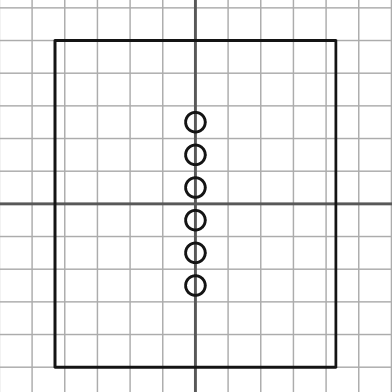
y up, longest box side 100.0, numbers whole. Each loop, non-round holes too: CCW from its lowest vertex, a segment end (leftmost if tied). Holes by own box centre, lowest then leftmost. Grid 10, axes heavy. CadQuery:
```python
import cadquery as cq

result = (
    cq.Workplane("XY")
    .moveTo(-43.0, -50.0)
    .lineTo(43.0, -50.0)
    .lineTo(43.0, 50.0)
    .lineTo(-43.0, 50.0)
    .close()
    .moveTo(0.0, -25.0)
    .circle(3.0)
    .moveTo(0.0, -15.0)
    .circle(3.0)
    .moveTo(0.0, -5.0)
    .circle(3.0)
    .moveTo(0.0, 5.0)
    .circle(3.0)
    .moveTo(0.0, 15.0)
    .circle(3.0)
    .moveTo(0.0, 25.0)
    .circle(3.0)
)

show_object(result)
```